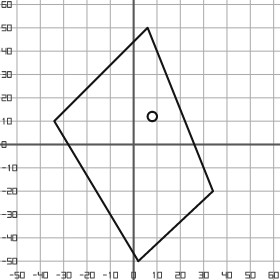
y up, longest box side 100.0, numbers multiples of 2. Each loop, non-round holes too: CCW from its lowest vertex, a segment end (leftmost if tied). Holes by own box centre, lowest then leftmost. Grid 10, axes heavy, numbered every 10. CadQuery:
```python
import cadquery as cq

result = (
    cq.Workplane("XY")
    .moveTo(2.0, -50.0)
    .lineTo(34.0, -20.0)
    .lineTo(6.0, 50.0)
    .lineTo(-34.0, 10.0)
    .close()
    .moveTo(8.0, 12.0)
    .circle(2.0)
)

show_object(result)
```